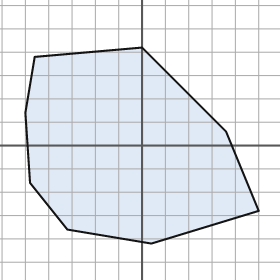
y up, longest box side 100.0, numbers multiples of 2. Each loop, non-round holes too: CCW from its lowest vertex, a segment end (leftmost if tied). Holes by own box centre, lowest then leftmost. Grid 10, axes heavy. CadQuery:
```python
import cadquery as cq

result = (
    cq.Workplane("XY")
    .moveTo(4.0, -42.0)
    .lineTo(50.0, -28.0)
    .lineTo(36.0, 6.0)
    .lineTo(0.0, 42.0)
    .lineTo(-46.0, 38.0)
    .lineTo(-50.0, 14.0)
    .lineTo(-48.0, -16.0)
    .lineTo(-32.0, -36.0)
    .close()
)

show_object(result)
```